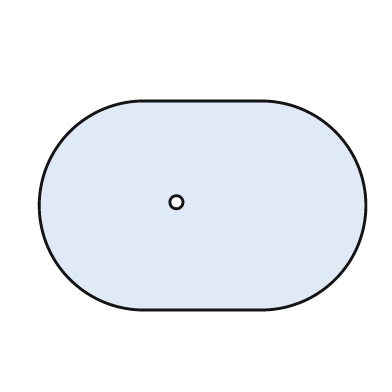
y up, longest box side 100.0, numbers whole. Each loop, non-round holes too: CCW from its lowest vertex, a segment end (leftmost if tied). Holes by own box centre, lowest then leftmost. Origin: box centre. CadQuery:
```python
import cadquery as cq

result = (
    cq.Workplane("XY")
    .moveTo(-18.0, -32.0)
    .lineTo(18.0, -32.0)
    .threePointArc((50.0, 0.0), (18.0, 32.0))
    .lineTo(-18.0, 32.0)
    .threePointArc((-50.0, 0.0), (-18.0, -32.0))
    .close()
    .moveTo(-8.0, 1.0)
    .circle(2.0)
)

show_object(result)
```